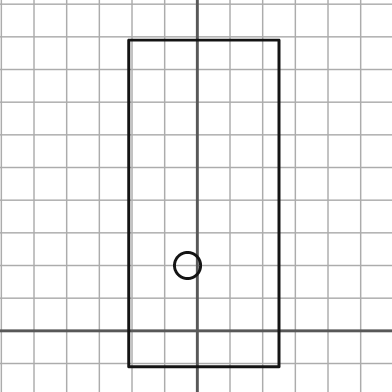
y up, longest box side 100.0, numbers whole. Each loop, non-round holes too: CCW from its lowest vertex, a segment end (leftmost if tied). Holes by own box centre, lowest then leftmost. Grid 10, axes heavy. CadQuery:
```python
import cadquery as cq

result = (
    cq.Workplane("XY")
    .moveTo(-21.0, -11.0)
    .lineTo(25.0, -11.0)
    .lineTo(25.0, 89.0)
    .lineTo(-21.0, 89.0)
    .close()
    .moveTo(-3.0, 20.0)
    .circle(4.0)
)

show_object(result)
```